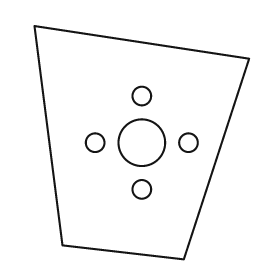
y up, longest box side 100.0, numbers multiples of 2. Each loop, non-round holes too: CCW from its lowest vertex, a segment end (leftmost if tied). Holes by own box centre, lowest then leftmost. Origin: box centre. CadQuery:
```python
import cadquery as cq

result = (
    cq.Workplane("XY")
    .moveTo(18.0, -50.0)
    .lineTo(46.0, 36.0)
    .lineTo(-46.0, 50.0)
    .lineTo(-34.0, -44.0)
    .close()
    .moveTo(0.0, -20.0)
    .circle(4.0)
    .moveTo(-20.0, 0.0)
    .circle(4.0)
    .moveTo(0.0, 0.0)
    .circle(10.0)
    .moveTo(20.0, 0.0)
    .circle(4.0)
    .moveTo(0.0, 20.0)
    .circle(4.0)
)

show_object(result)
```